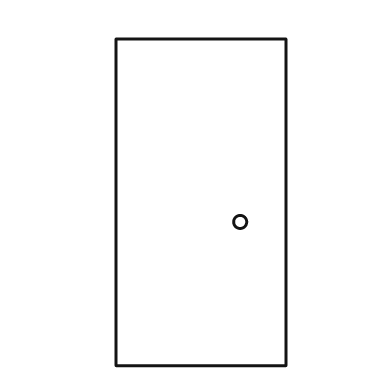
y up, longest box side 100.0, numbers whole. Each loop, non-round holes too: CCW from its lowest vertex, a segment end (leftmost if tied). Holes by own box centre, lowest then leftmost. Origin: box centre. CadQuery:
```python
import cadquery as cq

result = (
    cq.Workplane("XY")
    .moveTo(-26.0, -50.0)
    .lineTo(26.0, -50.0)
    .lineTo(26.0, 50.0)
    .lineTo(-26.0, 50.0)
    .close()
    .moveTo(12.0, -6.0)
    .circle(2.0)
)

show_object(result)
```